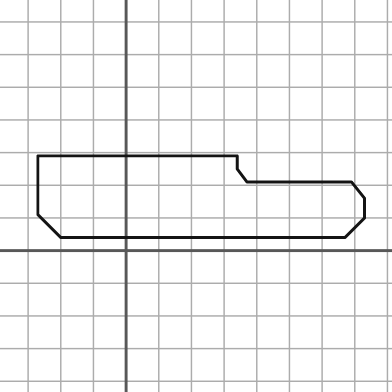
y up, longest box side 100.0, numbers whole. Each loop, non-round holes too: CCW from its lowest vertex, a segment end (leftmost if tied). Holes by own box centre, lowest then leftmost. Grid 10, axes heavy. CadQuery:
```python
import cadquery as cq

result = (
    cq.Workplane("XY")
    .moveTo(-20.0, 4.0)
    .lineTo(67.0, 4.0)
    .lineTo(73.0, 10.0)
    .lineTo(73.0, 16.0)
    .lineTo(69.0, 21.0)
    .lineTo(37.0, 21.0)
    .lineTo(34.0, 25.0)
    .lineTo(34.0, 29.0)
    .lineTo(-27.0, 29.0)
    .lineTo(-27.0, 11.0)
    .close()
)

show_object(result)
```